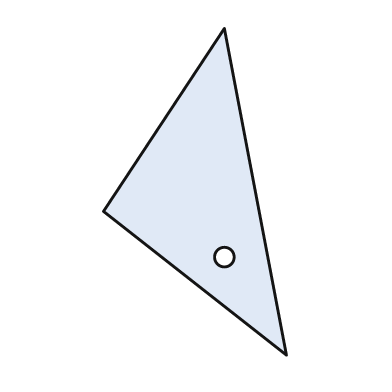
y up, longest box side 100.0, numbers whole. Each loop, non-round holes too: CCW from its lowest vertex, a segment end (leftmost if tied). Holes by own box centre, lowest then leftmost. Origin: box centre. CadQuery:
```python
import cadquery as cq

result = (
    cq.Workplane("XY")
    .moveTo(28.0, -50.0)
    .lineTo(9.0, 50.0)
    .lineTo(-28.0, -6.0)
    .close()
    .moveTo(9.0, -20.0)
    .circle(3.0)
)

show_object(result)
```